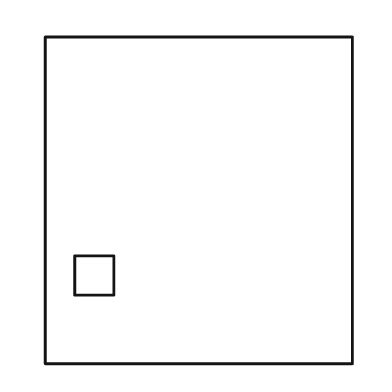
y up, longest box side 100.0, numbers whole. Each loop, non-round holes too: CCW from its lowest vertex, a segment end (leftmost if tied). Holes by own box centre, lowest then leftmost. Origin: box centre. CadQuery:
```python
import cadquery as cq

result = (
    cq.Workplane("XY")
    .moveTo(-47.0, -50.0)
    .lineTo(47.0, -50.0)
    .lineTo(47.0, 50.0)
    .lineTo(-47.0, 50.0)
    .close()
    .moveTo(-38.0, -29.0)
    .lineTo(-26.0, -29.0)
    .lineTo(-26.0, -17.0)
    .lineTo(-38.0, -17.0)
    .close()
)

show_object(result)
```